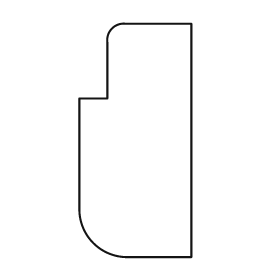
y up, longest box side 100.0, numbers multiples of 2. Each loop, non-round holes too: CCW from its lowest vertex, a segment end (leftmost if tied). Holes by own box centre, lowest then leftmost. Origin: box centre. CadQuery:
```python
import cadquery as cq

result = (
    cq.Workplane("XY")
    .moveTo(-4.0, -50.0)
    .lineTo(24.0, -50.0)
    .lineTo(24.0, 50.0)
    .lineTo(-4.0, 50.0)
    .threePointArc((-10.0, 48.0), (-12.0, 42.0))
    .lineTo(-12.0, 18.0)
    .lineTo(-24.0, 18.0)
    .lineTo(-24.0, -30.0)
    .threePointArc((-18.0, -44.0), (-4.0, -50.0))
    .close()
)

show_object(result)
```